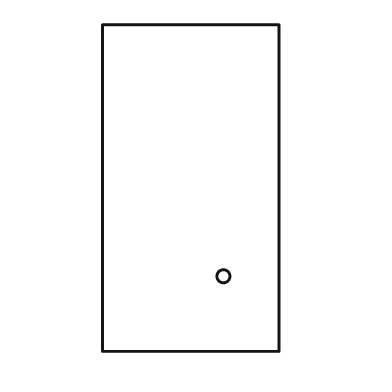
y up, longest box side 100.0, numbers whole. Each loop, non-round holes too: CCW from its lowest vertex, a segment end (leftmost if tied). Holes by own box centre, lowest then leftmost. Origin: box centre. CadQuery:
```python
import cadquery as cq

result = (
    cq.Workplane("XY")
    .moveTo(-27.0, -50.0)
    .lineTo(27.0, -50.0)
    .lineTo(27.0, 50.0)
    .lineTo(-27.0, 50.0)
    .close()
    .moveTo(10.0, -27.0)
    .circle(2.0)
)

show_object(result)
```